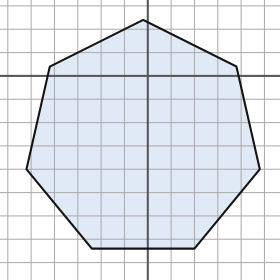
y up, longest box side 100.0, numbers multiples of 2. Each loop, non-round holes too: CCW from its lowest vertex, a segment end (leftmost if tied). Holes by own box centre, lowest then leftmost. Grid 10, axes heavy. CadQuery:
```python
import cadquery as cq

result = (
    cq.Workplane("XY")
    .moveTo(-24.0, -74.0)
    .lineTo(20.0, -74.0)
    .lineTo(48.0, -40.0)
    .lineTo(38.0, 4.0)
    .lineTo(-2.0, 24.0)
    .lineTo(-42.0, 4.0)
    .lineTo(-52.0, -40.0)
    .close()
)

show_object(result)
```